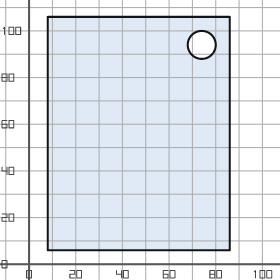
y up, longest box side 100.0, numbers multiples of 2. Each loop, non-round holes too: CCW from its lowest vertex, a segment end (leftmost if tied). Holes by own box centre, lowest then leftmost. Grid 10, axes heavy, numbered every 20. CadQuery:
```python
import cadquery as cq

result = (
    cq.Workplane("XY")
    .moveTo(8.0, 6.0)
    .lineTo(86.0, 6.0)
    .lineTo(86.0, 106.0)
    .lineTo(8.0, 106.0)
    .close()
    .moveTo(74.0, 94.0)
    .circle(6.0)
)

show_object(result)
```